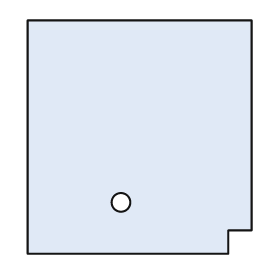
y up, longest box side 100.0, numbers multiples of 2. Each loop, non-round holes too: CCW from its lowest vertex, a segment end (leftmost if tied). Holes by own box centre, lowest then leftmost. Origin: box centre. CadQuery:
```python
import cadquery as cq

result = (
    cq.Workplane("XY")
    .moveTo(-48.0, -50.0)
    .lineTo(38.0, -50.0)
    .lineTo(38.0, -40.0)
    .lineTo(48.0, -40.0)
    .lineTo(48.0, 50.0)
    .lineTo(-48.0, 50.0)
    .close()
    .moveTo(-8.0, -28.0)
    .circle(4.0)
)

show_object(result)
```